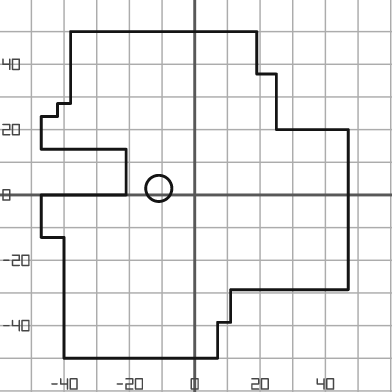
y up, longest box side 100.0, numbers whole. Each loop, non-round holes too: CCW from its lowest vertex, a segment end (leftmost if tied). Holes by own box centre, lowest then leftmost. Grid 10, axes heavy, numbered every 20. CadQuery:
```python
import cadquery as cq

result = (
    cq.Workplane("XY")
    .moveTo(-40.0, -50.0)
    .lineTo(7.0, -50.0)
    .lineTo(7.0, -39.0)
    .lineTo(11.0, -39.0)
    .lineTo(11.0, -29.0)
    .lineTo(47.0, -29.0)
    .lineTo(47.0, 20.0)
    .lineTo(25.0, 20.0)
    .lineTo(25.0, 37.0)
    .lineTo(19.0, 37.0)
    .lineTo(19.0, 50.0)
    .lineTo(-38.0, 50.0)
    .lineTo(-38.0, 28.0)
    .lineTo(-42.0, 28.0)
    .lineTo(-42.0, 24.0)
    .lineTo(-47.0, 24.0)
    .lineTo(-47.0, 14.0)
    .lineTo(-21.0, 14.0)
    .lineTo(-21.0, 0.0)
    .lineTo(-47.0, 0.0)
    .lineTo(-47.0, -13.0)
    .lineTo(-40.0, -13.0)
    .close()
    .moveTo(-11.0, 2.0)
    .circle(4.0)
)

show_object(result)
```